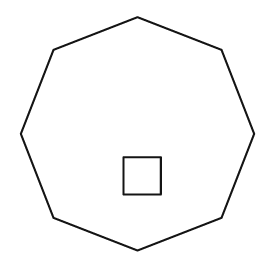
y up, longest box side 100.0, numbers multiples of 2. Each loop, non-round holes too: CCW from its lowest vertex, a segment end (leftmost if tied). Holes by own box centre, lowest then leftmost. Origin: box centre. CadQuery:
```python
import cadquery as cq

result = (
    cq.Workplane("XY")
    .moveTo(0.0, -50.0)
    .lineTo(36.0, -36.0)
    .lineTo(50.0, 0.0)
    .lineTo(36.0, 36.0)
    .lineTo(0.0, 50.0)
    .lineTo(-36.0, 36.0)
    .lineTo(-50.0, 0.0)
    .lineTo(-36.0, -36.0)
    .close()
    .moveTo(-6.0, -26.0)
    .lineTo(10.0, -26.0)
    .lineTo(10.0, -10.0)
    .lineTo(-6.0, -10.0)
    .close()
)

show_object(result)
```